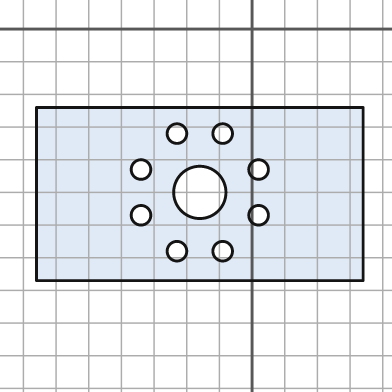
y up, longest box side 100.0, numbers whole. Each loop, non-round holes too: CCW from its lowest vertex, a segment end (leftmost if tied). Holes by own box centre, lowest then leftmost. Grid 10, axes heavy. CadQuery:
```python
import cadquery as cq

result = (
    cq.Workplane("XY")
    .moveTo(-66.0, -77.0)
    .lineTo(34.0, -77.0)
    .lineTo(34.0, -24.0)
    .lineTo(-66.0, -24.0)
    .close()
    .moveTo(-23.0, -68.0)
    .circle(3.0)
    .moveTo(-9.0, -68.0)
    .circle(3.0)
    .moveTo(-34.0, -57.0)
    .circle(3.0)
    .moveTo(2.0, -57.0)
    .circle(3.0)
    .moveTo(-16.0, -50.0)
    .circle(8.0)
    .moveTo(-34.0, -43.0)
    .circle(3.0)
    .moveTo(2.0, -43.0)
    .circle(3.0)
    .moveTo(-23.0, -32.0)
    .circle(3.0)
    .moveTo(-9.0, -32.0)
    .circle(3.0)
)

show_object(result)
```